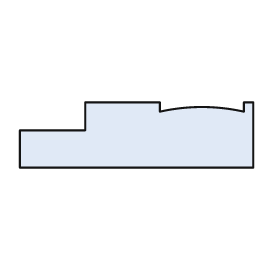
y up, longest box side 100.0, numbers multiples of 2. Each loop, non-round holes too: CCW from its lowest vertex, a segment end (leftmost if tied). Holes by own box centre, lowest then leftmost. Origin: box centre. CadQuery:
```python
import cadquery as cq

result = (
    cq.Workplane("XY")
    .moveTo(-50.0, -14.0)
    .lineTo(50.0, -14.0)
    .lineTo(50.0, 14.0)
    .lineTo(46.0, 14.0)
    .lineTo(46.0, 10.0)
    .threePointArc((28.0, 12.0), (10.0, 10.0))
    .lineTo(10.0, 14.0)
    .lineTo(-22.0, 14.0)
    .lineTo(-22.0, 2.0)
    .lineTo(-50.0, 2.0)
    .close()
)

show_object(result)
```